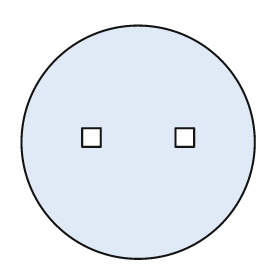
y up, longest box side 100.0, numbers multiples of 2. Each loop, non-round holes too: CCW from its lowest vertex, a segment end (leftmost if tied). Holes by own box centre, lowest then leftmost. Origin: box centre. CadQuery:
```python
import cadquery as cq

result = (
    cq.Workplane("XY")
    .moveTo(0.0, 0.0)
    .circle(50.0)
    .moveTo(-24.0, -2.0)
    .lineTo(-16.0, -2.0)
    .lineTo(-16.0, 6.0)
    .lineTo(-24.0, 6.0)
    .close()
    .moveTo(16.0, -2.0)
    .lineTo(24.0, -2.0)
    .lineTo(24.0, 6.0)
    .lineTo(16.0, 6.0)
    .close()
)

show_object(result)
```